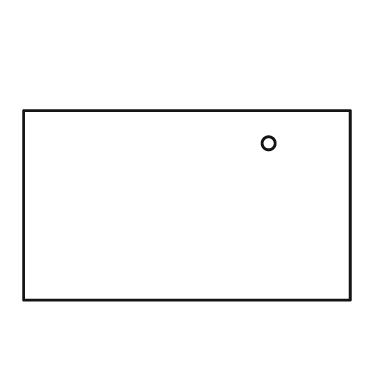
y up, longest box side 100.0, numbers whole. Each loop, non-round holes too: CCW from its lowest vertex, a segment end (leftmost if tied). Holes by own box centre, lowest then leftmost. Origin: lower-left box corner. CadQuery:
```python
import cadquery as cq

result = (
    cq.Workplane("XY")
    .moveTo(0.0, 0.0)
    .lineTo(100.0, 0.0)
    .lineTo(100.0, 58.0)
    .lineTo(0.0, 58.0)
    .close()
    .moveTo(75.0, 48.0)
    .circle(2.0)
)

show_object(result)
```